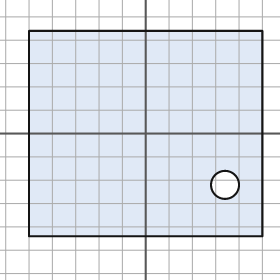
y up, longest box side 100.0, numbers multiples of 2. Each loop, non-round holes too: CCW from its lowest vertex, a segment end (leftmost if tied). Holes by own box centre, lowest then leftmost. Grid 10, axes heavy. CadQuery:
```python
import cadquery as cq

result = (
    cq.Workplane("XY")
    .moveTo(-50.0, -44.0)
    .lineTo(50.0, -44.0)
    .lineTo(50.0, 44.0)
    .lineTo(-50.0, 44.0)
    .close()
    .moveTo(34.0, -22.0)
    .circle(6.0)
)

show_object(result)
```